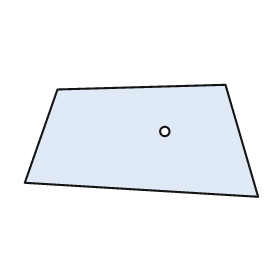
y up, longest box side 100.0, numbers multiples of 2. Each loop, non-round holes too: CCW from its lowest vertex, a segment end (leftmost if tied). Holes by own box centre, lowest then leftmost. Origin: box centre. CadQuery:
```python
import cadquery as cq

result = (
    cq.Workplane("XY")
    .moveTo(50.0, -24.0)
    .lineTo(36.0, 24.0)
    .lineTo(-36.0, 22.0)
    .lineTo(-50.0, -18.0)
    .close()
    .moveTo(10.0, 4.0)
    .circle(2.0)
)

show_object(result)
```